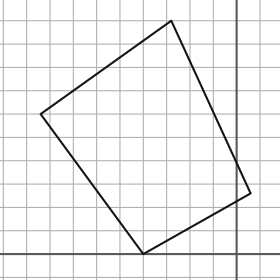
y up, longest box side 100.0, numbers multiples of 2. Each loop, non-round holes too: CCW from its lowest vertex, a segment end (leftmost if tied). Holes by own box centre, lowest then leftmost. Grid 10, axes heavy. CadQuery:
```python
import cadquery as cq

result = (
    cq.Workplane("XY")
    .moveTo(-40.0, 0.0)
    .lineTo(6.0, 26.0)
    .lineTo(-28.0, 100.0)
    .lineTo(-84.0, 60.0)
    .close()
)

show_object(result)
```